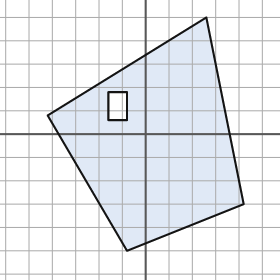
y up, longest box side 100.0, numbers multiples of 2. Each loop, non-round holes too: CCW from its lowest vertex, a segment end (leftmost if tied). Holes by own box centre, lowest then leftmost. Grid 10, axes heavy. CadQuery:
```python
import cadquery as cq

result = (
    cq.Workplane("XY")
    .moveTo(-8.0, -50.0)
    .lineTo(42.0, -30.0)
    .lineTo(26.0, 50.0)
    .lineTo(-42.0, 8.0)
    .close()
    .moveTo(-16.0, 6.0)
    .lineTo(-8.0, 6.0)
    .lineTo(-8.0, 18.0)
    .lineTo(-16.0, 18.0)
    .close()
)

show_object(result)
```